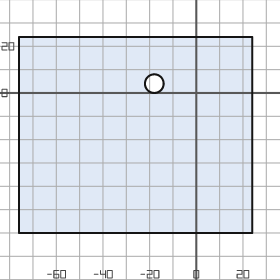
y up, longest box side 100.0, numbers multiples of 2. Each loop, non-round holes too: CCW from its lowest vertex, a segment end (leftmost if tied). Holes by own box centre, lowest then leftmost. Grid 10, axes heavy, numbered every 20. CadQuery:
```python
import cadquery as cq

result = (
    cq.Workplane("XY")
    .moveTo(-76.0, -60.0)
    .lineTo(24.0, -60.0)
    .lineTo(24.0, 24.0)
    .lineTo(-76.0, 24.0)
    .close()
    .moveTo(-18.0, 4.0)
    .circle(4.0)
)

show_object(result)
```